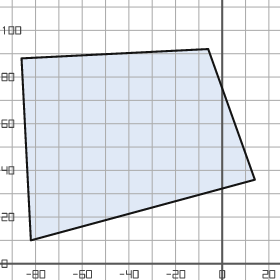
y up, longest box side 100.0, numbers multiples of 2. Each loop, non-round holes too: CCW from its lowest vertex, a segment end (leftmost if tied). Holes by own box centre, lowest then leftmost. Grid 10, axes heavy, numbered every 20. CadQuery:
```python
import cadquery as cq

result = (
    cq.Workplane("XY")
    .moveTo(-82.0, 10.0)
    .lineTo(14.0, 36.0)
    .lineTo(-6.0, 92.0)
    .lineTo(-86.0, 88.0)
    .close()
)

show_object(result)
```